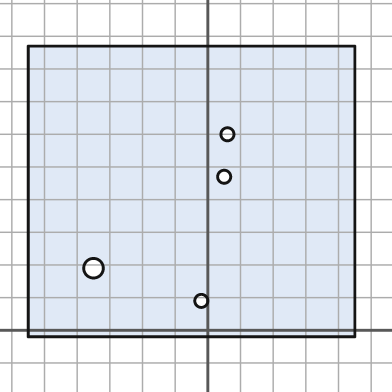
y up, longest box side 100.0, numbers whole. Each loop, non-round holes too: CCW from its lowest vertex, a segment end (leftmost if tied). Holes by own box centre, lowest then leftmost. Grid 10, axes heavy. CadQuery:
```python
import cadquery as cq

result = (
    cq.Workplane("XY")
    .moveTo(-55.0, -2.0)
    .lineTo(45.0, -2.0)
    .lineTo(45.0, 87.0)
    .lineTo(-55.0, 87.0)
    .close()
    .moveTo(-2.0, 9.0)
    .circle(2.0)
    .moveTo(-35.0, 19.0)
    .circle(3.0)
    .moveTo(5.0, 47.0)
    .circle(2.0)
    .moveTo(6.0, 60.0)
    .circle(2.0)
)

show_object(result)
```